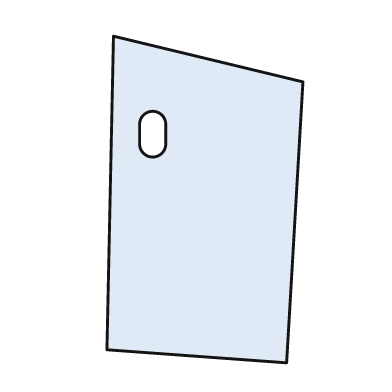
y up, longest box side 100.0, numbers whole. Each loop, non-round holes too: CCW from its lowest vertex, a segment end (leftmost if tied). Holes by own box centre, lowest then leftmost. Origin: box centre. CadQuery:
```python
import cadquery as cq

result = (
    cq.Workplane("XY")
    .moveTo(25.0, -50.0)
    .lineTo(30.0, 36.0)
    .lineTo(-28.0, 50.0)
    .lineTo(-30.0, -46.0)
    .close()
    .moveTo(-20.0, 17.0)
    .threePointArc((-16.0, 13.0), (-12.0, 17.0))
    .lineTo(-12.0, 23.0)
    .threePointArc((-16.0, 27.0), (-20.0, 23.0))
    .close()
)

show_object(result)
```